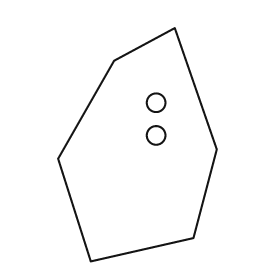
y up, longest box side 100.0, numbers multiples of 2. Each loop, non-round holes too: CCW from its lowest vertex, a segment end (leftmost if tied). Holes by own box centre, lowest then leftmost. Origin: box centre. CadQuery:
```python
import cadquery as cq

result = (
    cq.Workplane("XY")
    .moveTo(-20.0, -50.0)
    .lineTo(24.0, -40.0)
    .lineTo(34.0, -2.0)
    .lineTo(16.0, 50.0)
    .lineTo(-10.0, 36.0)
    .lineTo(-34.0, -6.0)
    .close()
    .moveTo(8.0, 4.0)
    .circle(4.0)
    .moveTo(8.0, 18.0)
    .circle(4.0)
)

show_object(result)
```